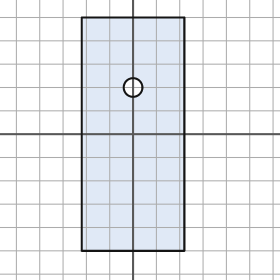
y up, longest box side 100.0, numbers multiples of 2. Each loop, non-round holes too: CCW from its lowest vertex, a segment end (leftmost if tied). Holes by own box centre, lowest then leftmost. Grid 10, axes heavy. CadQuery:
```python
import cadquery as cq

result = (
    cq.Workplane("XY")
    .moveTo(-22.0, -50.0)
    .lineTo(22.0, -50.0)
    .lineTo(22.0, 50.0)
    .lineTo(-22.0, 50.0)
    .close()
    .moveTo(0.0, 20.0)
    .circle(4.0)
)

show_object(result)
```